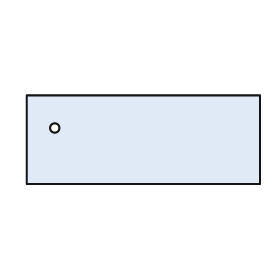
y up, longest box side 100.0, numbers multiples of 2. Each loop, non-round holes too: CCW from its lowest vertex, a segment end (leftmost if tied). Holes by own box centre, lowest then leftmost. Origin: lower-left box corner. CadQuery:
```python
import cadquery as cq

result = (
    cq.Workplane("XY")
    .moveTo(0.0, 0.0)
    .lineTo(100.0, 0.0)
    .lineTo(100.0, 38.0)
    .lineTo(0.0, 38.0)
    .close()
    .moveTo(12.0, 24.0)
    .circle(2.0)
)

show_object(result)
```